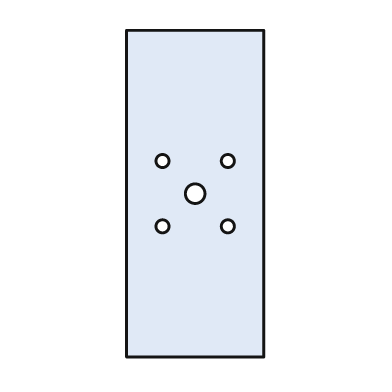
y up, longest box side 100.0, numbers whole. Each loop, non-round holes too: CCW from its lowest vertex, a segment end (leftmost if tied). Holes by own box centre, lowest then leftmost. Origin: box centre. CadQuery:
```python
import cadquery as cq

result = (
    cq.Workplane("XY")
    .moveTo(-21.0, -50.0)
    .lineTo(21.0, -50.0)
    .lineTo(21.0, 50.0)
    .lineTo(-21.0, 50.0)
    .close()
    .moveTo(-10.0, -10.0)
    .circle(2.0)
    .moveTo(10.0, -10.0)
    .circle(2.0)
    .moveTo(0.0, 0.0)
    .circle(3.0)
    .moveTo(-10.0, 10.0)
    .circle(2.0)
    .moveTo(10.0, 10.0)
    .circle(2.0)
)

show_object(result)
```